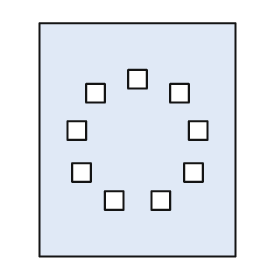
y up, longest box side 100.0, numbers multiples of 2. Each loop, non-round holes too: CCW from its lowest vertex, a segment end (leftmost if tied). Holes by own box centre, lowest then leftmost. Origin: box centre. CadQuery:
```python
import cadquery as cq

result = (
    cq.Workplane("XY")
    .moveTo(-42.0, -50.0)
    .lineTo(42.0, -50.0)
    .lineTo(42.0, 50.0)
    .lineTo(-42.0, 50.0)
    .close()
    .moveTo(-14.0, -30.0)
    .lineTo(-6.0, -30.0)
    .lineTo(-6.0, -22.0)
    .lineTo(-14.0, -22.0)
    .close()
    .moveTo(6.0, -30.0)
    .lineTo(14.0, -30.0)
    .lineTo(14.0, -22.0)
    .lineTo(6.0, -22.0)
    .close()
    .moveTo(-28.0, -18.0)
    .lineTo(-20.0, -18.0)
    .lineTo(-20.0, -10.0)
    .lineTo(-28.0, -10.0)
    .close()
    .moveTo(20.0, -18.0)
    .lineTo(28.0, -18.0)
    .lineTo(28.0, -10.0)
    .lineTo(20.0, -10.0)
    .close()
    .moveTo(-30.0, 0.0)
    .lineTo(-22.0, 0.0)
    .lineTo(-22.0, 8.0)
    .lineTo(-30.0, 8.0)
    .close()
    .moveTo(22.0, 0.0)
    .lineTo(30.0, 0.0)
    .lineTo(30.0, 8.0)
    .lineTo(22.0, 8.0)
    .close()
    .moveTo(-22.0, 16.0)
    .lineTo(-14.0, 16.0)
    .lineTo(-14.0, 24.0)
    .lineTo(-22.0, 24.0)
    .close()
    .moveTo(14.0, 16.0)
    .lineTo(22.0, 16.0)
    .lineTo(22.0, 24.0)
    .lineTo(14.0, 24.0)
    .close()
    .moveTo(-4.0, 22.0)
    .lineTo(4.0, 22.0)
    .lineTo(4.0, 30.0)
    .lineTo(-4.0, 30.0)
    .close()
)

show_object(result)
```